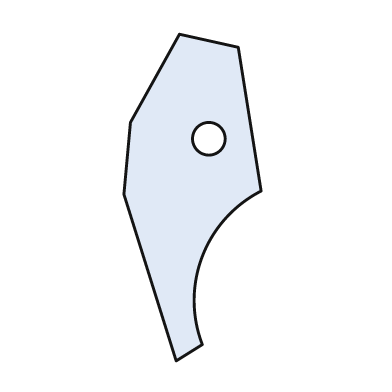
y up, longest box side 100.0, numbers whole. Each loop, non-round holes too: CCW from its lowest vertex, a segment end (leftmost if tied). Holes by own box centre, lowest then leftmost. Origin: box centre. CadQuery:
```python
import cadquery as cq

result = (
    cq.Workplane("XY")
    .moveTo(-5.0, -50.0)
    .lineTo(3.0, -45.0)
    .threePointArc((3.0, -18.0), (21.0, 2.0))
    .lineTo(14.0, 46.0)
    .lineTo(-4.0, 50.0)
    .lineTo(-19.0, 23.0)
    .lineTo(-21.0, 1.0)
    .close()
    .moveTo(5.0, 18.0)
    .circle(5.0)
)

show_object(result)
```